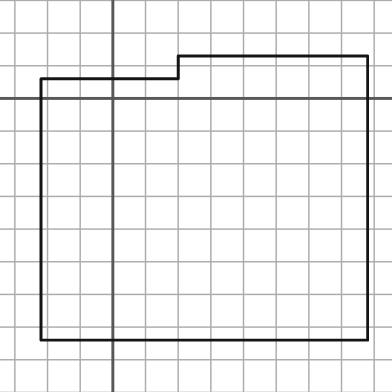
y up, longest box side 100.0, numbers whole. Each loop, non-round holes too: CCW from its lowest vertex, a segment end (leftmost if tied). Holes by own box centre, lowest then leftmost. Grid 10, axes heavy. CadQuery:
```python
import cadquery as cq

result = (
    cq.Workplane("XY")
    .moveTo(-22.0, -74.0)
    .lineTo(78.0, -74.0)
    .lineTo(78.0, 13.0)
    .lineTo(20.0, 13.0)
    .lineTo(20.0, 6.0)
    .lineTo(-22.0, 6.0)
    .close()
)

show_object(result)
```